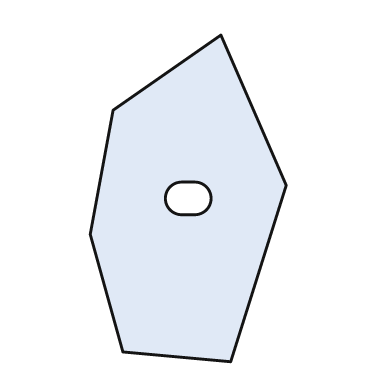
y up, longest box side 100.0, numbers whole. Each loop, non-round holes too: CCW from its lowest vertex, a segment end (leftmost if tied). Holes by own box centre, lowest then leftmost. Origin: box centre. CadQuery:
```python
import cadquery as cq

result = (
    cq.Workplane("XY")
    .moveTo(13.0, -50.0)
    .lineTo(30.0, 4.0)
    .lineTo(10.0, 50.0)
    .lineTo(-23.0, 27.0)
    .lineTo(-30.0, -11.0)
    .lineTo(-20.0, -47.0)
    .close()
    .moveTo(-2.0, -5.0)
    .lineTo(2.0, -5.0)
    .threePointArc((7.0, 0.0), (2.0, 5.0))
    .lineTo(-2.0, 5.0)
    .threePointArc((-7.0, 0.0), (-2.0, -5.0))
    .close()
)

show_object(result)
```